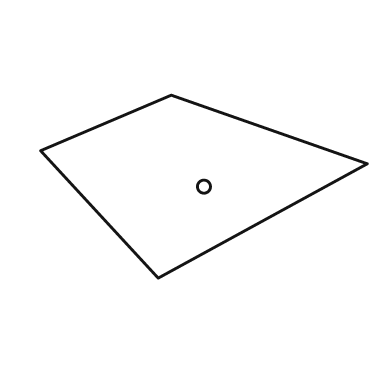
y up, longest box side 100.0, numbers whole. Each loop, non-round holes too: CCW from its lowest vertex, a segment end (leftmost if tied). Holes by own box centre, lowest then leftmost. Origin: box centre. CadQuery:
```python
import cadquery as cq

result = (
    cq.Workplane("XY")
    .moveTo(-14.0, -28.0)
    .lineTo(50.0, 7.0)
    .lineTo(-10.0, 28.0)
    .lineTo(-50.0, 11.0)
    .close()
    .moveTo(0.0, 0.0)
    .circle(2.0)
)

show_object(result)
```